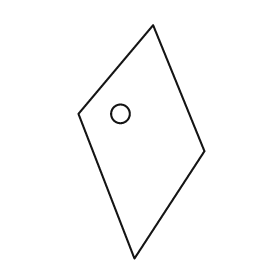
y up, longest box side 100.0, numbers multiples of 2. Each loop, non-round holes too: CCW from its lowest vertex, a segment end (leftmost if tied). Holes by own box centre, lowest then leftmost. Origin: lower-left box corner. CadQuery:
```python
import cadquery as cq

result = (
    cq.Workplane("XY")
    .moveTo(24.0, 0.0)
    .lineTo(54.0, 46.0)
    .lineTo(32.0, 100.0)
    .lineTo(0.0, 62.0)
    .close()
    .moveTo(18.0, 62.0)
    .circle(4.0)
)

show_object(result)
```